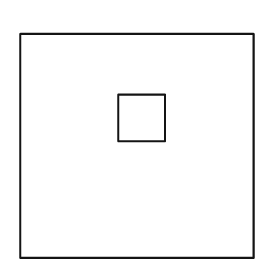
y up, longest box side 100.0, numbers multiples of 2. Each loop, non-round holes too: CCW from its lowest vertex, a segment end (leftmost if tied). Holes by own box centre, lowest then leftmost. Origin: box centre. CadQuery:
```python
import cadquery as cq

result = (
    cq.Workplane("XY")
    .moveTo(-50.0, -48.0)
    .lineTo(50.0, -48.0)
    .lineTo(50.0, 48.0)
    .lineTo(-50.0, 48.0)
    .close()
    .moveTo(-8.0, 2.0)
    .lineTo(12.0, 2.0)
    .lineTo(12.0, 22.0)
    .lineTo(-8.0, 22.0)
    .close()
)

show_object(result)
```